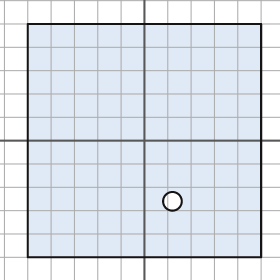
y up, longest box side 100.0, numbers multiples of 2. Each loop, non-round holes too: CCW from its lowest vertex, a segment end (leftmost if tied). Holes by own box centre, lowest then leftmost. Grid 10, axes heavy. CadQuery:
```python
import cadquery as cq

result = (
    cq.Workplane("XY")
    .moveTo(-50.0, -50.0)
    .lineTo(50.0, -50.0)
    .lineTo(50.0, 50.0)
    .lineTo(-50.0, 50.0)
    .close()
    .moveTo(12.0, -26.0)
    .circle(4.0)
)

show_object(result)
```